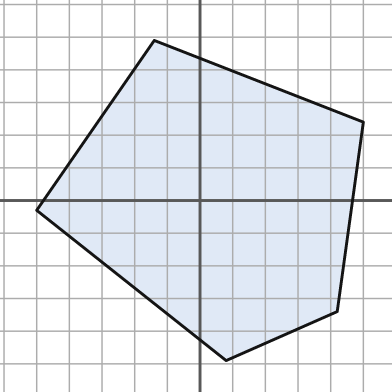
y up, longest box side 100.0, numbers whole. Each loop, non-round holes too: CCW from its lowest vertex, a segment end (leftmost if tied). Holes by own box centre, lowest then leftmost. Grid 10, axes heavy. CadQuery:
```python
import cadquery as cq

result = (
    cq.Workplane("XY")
    .moveTo(8.0, -49.0)
    .lineTo(42.0, -34.0)
    .lineTo(50.0, 24.0)
    .lineTo(-14.0, 49.0)
    .lineTo(-50.0, -3.0)
    .close()
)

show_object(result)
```